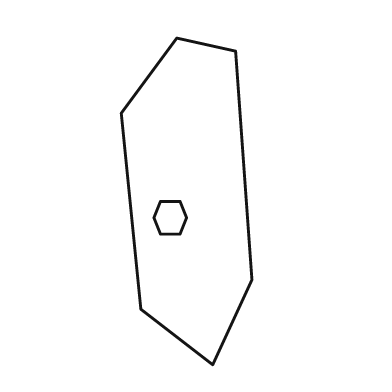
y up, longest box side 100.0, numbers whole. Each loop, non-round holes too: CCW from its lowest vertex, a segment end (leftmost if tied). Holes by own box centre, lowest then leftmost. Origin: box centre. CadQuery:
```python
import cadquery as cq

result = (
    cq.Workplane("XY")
    .moveTo(8.0, -50.0)
    .lineTo(20.0, -24.0)
    .lineTo(15.0, 46.0)
    .lineTo(-3.0, 50.0)
    .lineTo(-20.0, 27.0)
    .lineTo(-14.0, -33.0)
    .close()
    .moveTo(-8.0, -10.0)
    .lineTo(-2.0, -10.0)
    .lineTo(0.0, -5.0)
    .lineTo(-2.0, 0.0)
    .lineTo(-8.0, 0.0)
    .lineTo(-10.0, -5.0)
    .close()
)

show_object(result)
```